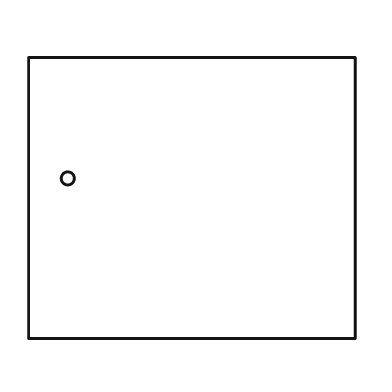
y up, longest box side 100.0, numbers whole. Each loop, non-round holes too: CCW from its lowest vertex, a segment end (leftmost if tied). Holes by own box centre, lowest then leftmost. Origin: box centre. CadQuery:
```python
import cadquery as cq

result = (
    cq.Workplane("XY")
    .moveTo(-50.0, -43.0)
    .lineTo(50.0, -43.0)
    .lineTo(50.0, 43.0)
    .lineTo(-50.0, 43.0)
    .close()
    .moveTo(-38.0, 6.0)
    .circle(2.0)
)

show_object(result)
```